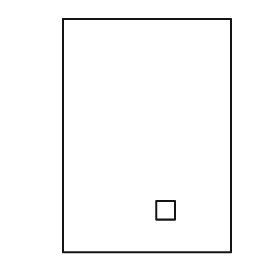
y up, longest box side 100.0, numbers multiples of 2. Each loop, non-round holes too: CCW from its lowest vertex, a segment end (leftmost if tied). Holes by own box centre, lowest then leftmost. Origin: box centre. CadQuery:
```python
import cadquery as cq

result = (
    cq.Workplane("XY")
    .moveTo(-36.0, -50.0)
    .lineTo(36.0, -50.0)
    .lineTo(36.0, 50.0)
    .lineTo(-36.0, 50.0)
    .close()
    .moveTo(4.0, -36.0)
    .lineTo(12.0, -36.0)
    .lineTo(12.0, -28.0)
    .lineTo(4.0, -28.0)
    .close()
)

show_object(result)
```